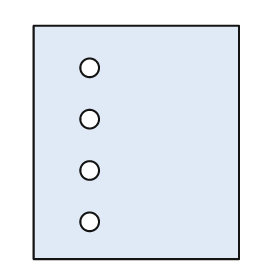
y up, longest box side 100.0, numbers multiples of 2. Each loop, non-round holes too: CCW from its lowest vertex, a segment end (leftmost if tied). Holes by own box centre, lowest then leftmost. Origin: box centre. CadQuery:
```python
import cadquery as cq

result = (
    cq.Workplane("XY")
    .moveTo(-44.0, -50.0)
    .lineTo(44.0, -50.0)
    .lineTo(44.0, 50.0)
    .lineTo(-44.0, 50.0)
    .close()
    .moveTo(-20.0, -34.0)
    .circle(4.0)
    .moveTo(-20.0, -12.0)
    .circle(4.0)
    .moveTo(-20.0, 10.0)
    .circle(4.0)
    .moveTo(-20.0, 32.0)
    .circle(4.0)
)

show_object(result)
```